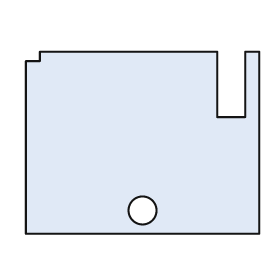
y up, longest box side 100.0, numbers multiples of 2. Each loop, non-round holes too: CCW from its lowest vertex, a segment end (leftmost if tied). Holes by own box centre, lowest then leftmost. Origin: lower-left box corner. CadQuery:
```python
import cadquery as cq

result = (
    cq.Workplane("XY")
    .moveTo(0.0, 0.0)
    .lineTo(100.0, 0.0)
    .lineTo(100.0, 78.0)
    .lineTo(94.0, 78.0)
    .lineTo(94.0, 50.0)
    .lineTo(82.0, 50.0)
    .lineTo(82.0, 78.0)
    .lineTo(6.0, 78.0)
    .lineTo(6.0, 74.0)
    .lineTo(0.0, 74.0)
    .close()
    .moveTo(50.0, 10.0)
    .circle(6.0)
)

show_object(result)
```